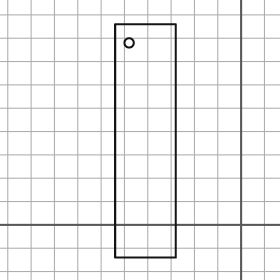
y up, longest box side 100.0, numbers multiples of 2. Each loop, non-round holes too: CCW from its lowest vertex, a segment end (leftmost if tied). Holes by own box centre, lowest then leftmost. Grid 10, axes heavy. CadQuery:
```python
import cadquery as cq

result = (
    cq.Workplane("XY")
    .moveTo(-54.0, -14.0)
    .lineTo(-28.0, -14.0)
    .lineTo(-28.0, 86.0)
    .lineTo(-54.0, 86.0)
    .close()
    .moveTo(-48.0, 78.0)
    .circle(2.0)
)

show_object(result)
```